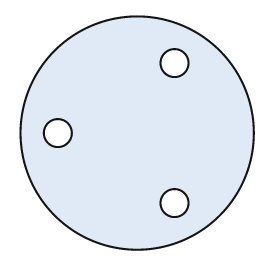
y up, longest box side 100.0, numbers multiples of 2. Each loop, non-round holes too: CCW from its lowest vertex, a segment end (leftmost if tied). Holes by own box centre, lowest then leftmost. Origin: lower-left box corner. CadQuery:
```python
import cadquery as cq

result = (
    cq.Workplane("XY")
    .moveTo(50.0, 50.0)
    .circle(50.0)
    .moveTo(66.0, 20.0)
    .circle(6.0)
    .moveTo(16.0, 50.0)
    .circle(6.0)
    .moveTo(66.0, 80.0)
    .circle(6.0)
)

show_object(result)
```